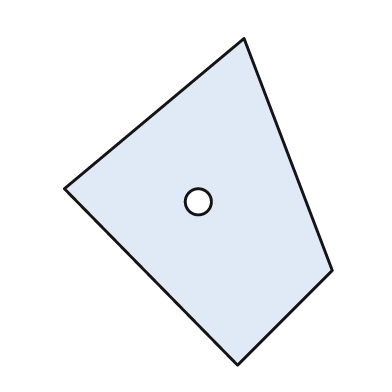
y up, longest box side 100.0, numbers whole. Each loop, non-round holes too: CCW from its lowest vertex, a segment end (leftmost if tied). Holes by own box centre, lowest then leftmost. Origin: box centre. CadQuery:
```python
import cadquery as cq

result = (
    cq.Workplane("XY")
    .moveTo(12.0, -50.0)
    .lineTo(41.0, -21.0)
    .lineTo(14.0, 50.0)
    .lineTo(-41.0, 4.0)
    .close()
    .moveTo(0.0, 0.0)
    .circle(4.0)
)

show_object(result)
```